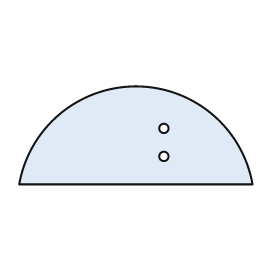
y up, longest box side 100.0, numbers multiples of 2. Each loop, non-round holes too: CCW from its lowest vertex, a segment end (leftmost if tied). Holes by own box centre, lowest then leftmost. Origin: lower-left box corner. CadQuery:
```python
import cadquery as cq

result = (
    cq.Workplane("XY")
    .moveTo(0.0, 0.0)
    .lineTo(100.0, 0.0)
    .threePointArc((50.0, 42.0), (0.0, 0.0))
    .close()
    .moveTo(62.0, 12.0)
    .circle(2.0)
    .moveTo(62.0, 24.0)
    .circle(2.0)
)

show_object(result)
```